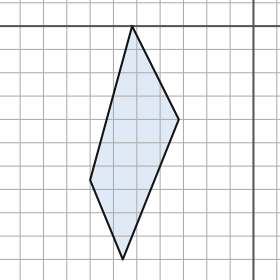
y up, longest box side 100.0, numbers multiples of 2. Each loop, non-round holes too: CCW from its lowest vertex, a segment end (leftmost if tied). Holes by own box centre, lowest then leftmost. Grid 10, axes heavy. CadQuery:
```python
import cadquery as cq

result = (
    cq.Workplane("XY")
    .moveTo(-56.0, -100.0)
    .lineTo(-32.0, -40.0)
    .lineTo(-52.0, 0.0)
    .lineTo(-70.0, -66.0)
    .close()
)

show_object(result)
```